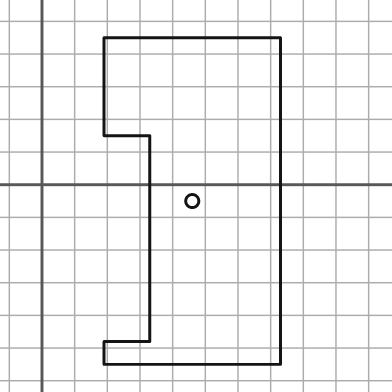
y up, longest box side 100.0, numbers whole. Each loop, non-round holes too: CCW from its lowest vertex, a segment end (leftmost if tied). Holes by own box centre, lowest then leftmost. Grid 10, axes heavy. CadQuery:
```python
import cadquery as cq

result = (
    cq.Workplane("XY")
    .moveTo(19.0, -55.0)
    .lineTo(73.0, -55.0)
    .lineTo(73.0, 45.0)
    .lineTo(19.0, 45.0)
    .lineTo(19.0, 15.0)
    .lineTo(33.0, 15.0)
    .lineTo(33.0, -48.0)
    .lineTo(19.0, -48.0)
    .close()
    .moveTo(46.0, -5.0)
    .circle(2.0)
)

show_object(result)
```